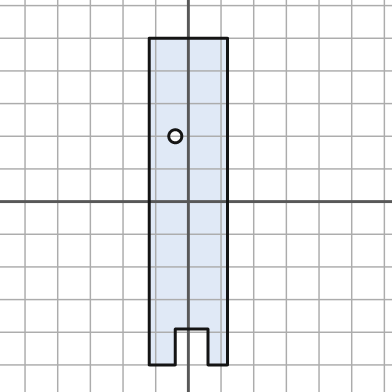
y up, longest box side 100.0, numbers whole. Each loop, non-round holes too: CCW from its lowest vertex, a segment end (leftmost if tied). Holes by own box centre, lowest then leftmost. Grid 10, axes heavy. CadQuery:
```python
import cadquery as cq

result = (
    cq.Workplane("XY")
    .moveTo(-12.0, -50.0)
    .lineTo(-4.0, -50.0)
    .lineTo(-4.0, -39.0)
    .lineTo(6.0, -39.0)
    .lineTo(6.0, -50.0)
    .lineTo(12.0, -50.0)
    .lineTo(12.0, 50.0)
    .lineTo(-12.0, 50.0)
    .close()
    .moveTo(-4.0, 20.0)
    .circle(2.0)
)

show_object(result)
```